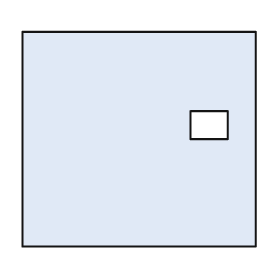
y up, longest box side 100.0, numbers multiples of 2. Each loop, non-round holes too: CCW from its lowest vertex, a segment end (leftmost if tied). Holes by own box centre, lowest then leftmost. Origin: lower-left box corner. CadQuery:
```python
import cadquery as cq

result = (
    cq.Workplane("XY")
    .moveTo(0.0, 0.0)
    .lineTo(100.0, 0.0)
    .lineTo(100.0, 92.0)
    .lineTo(0.0, 92.0)
    .close()
    .moveTo(72.0, 46.0)
    .lineTo(88.0, 46.0)
    .lineTo(88.0, 58.0)
    .lineTo(72.0, 58.0)
    .close()
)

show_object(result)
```